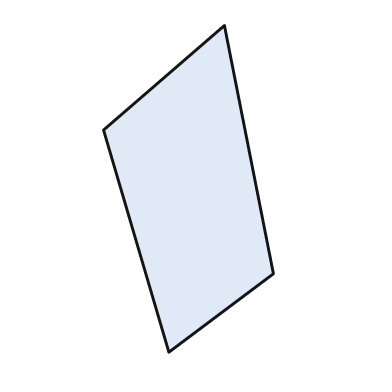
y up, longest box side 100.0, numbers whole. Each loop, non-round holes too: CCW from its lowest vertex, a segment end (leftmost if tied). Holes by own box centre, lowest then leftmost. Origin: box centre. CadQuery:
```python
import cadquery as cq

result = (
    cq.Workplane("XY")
    .moveTo(-6.0, -50.0)
    .lineTo(26.0, -26.0)
    .lineTo(11.0, 50.0)
    .lineTo(-26.0, 18.0)
    .close()
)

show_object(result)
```